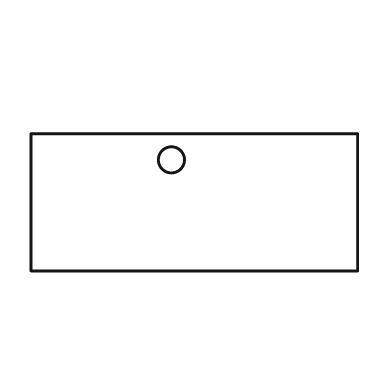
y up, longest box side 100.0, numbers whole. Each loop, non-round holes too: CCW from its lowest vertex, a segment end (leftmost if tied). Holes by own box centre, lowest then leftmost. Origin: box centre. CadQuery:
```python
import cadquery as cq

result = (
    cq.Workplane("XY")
    .moveTo(-50.0, -21.0)
    .lineTo(50.0, -21.0)
    .lineTo(50.0, 21.0)
    .lineTo(-50.0, 21.0)
    .close()
    .moveTo(-7.0, 13.0)
    .circle(4.0)
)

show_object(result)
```